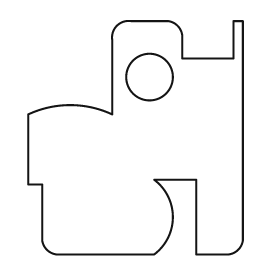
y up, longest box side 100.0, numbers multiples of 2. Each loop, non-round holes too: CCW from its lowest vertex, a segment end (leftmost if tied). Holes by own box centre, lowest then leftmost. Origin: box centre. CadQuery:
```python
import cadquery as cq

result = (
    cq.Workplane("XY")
    .moveTo(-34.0, -50.0)
    .lineTo(8.0, -50.0)
    .threePointArc((16.0, -34.0), (8.0, -18.0))
    .lineTo(26.0, -18.0)
    .lineTo(26.0, -50.0)
    .lineTo(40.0, -50.0)
    .threePointArc((44.0, -48.0), (46.0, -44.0))
    .lineTo(46.0, 50.0)
    .lineTo(42.0, 50.0)
    .lineTo(42.0, 34.0)
    .lineTo(20.0, 34.0)
    .lineTo(20.0, 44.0)
    .threePointArc((18.0, 48.0), (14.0, 50.0))
    .lineTo(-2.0, 50.0)
    .threePointArc((-8.0, 48.0), (-10.0, 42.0))
    .lineTo(-10.0, 10.0)
    .threePointArc((-28.0, 14.0), (-46.0, 10.0))
    .lineTo(-46.0, -20.0)
    .lineTo(-40.0, -20.0)
    .lineTo(-40.0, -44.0)
    .threePointArc((-38.0, -48.0), (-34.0, -50.0))
    .close()
    .moveTo(6.0, 26.0)
    .circle(10.0)
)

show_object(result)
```